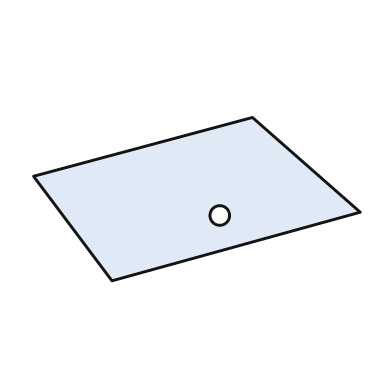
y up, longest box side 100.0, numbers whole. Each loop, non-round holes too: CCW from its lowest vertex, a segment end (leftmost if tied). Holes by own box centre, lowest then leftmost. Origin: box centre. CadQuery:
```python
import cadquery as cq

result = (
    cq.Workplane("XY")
    .moveTo(-26.0, -25.0)
    .lineTo(50.0, -4.0)
    .lineTo(17.0, 25.0)
    .lineTo(-50.0, 7.0)
    .close()
    .moveTo(7.0, -5.0)
    .circle(3.0)
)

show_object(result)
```